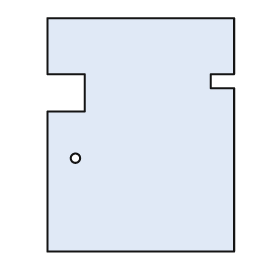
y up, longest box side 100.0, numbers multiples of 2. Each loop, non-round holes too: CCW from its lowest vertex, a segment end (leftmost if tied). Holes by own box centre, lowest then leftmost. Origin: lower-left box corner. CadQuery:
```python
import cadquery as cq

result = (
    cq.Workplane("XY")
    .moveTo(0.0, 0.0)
    .lineTo(80.0, 0.0)
    .lineTo(80.0, 70.0)
    .lineTo(70.0, 70.0)
    .lineTo(70.0, 76.0)
    .lineTo(80.0, 76.0)
    .lineTo(80.0, 100.0)
    .lineTo(0.0, 100.0)
    .lineTo(0.0, 76.0)
    .lineTo(16.0, 76.0)
    .lineTo(16.0, 60.0)
    .lineTo(0.0, 60.0)
    .close()
    .moveTo(12.0, 40.0)
    .circle(2.0)
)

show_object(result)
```